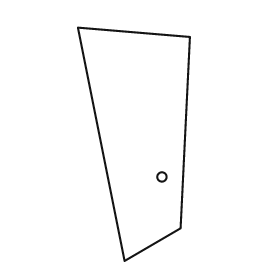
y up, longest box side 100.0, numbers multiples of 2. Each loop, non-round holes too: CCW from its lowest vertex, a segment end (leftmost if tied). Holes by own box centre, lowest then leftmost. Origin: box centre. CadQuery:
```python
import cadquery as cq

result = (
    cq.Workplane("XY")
    .moveTo(-4.0, -50.0)
    .lineTo(20.0, -36.0)
    .lineTo(24.0, 46.0)
    .lineTo(-24.0, 50.0)
    .close()
    .moveTo(12.0, -14.0)
    .circle(2.0)
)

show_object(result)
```